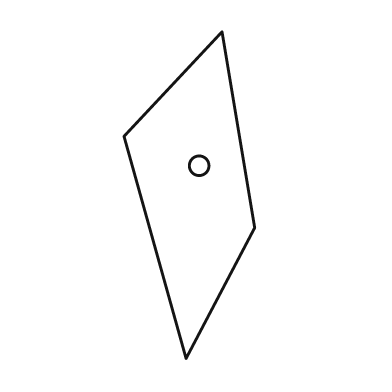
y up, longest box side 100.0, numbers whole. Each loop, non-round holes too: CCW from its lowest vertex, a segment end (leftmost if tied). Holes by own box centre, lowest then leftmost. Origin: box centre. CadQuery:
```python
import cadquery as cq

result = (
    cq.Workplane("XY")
    .moveTo(-1.0, -50.0)
    .lineTo(20.0, -10.0)
    .lineTo(10.0, 50.0)
    .lineTo(-20.0, 18.0)
    .close()
    .moveTo(3.0, 9.0)
    .circle(3.0)
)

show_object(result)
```